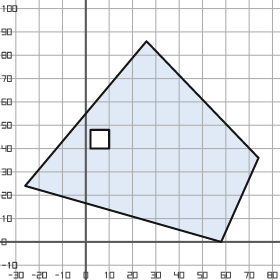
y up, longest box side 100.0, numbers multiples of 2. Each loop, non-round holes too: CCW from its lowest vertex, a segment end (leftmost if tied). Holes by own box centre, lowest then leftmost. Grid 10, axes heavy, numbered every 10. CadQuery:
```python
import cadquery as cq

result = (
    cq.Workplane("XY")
    .moveTo(58.0, 0.0)
    .lineTo(74.0, 36.0)
    .lineTo(26.0, 86.0)
    .lineTo(-26.0, 24.0)
    .close()
    .moveTo(2.0, 40.0)
    .lineTo(10.0, 40.0)
    .lineTo(10.0, 48.0)
    .lineTo(2.0, 48.0)
    .close()
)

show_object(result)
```